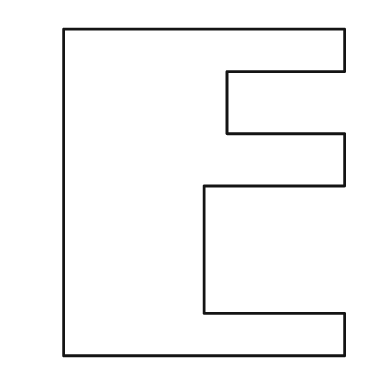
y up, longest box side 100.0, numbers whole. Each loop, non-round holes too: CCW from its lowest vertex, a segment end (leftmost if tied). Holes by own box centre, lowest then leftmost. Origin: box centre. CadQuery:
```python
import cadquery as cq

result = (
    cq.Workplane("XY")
    .moveTo(-43.0, -50.0)
    .lineTo(43.0, -50.0)
    .lineTo(43.0, -37.0)
    .lineTo(0.0, -37.0)
    .lineTo(0.0, 2.0)
    .lineTo(43.0, 2.0)
    .lineTo(43.0, 18.0)
    .lineTo(7.0, 18.0)
    .lineTo(7.0, 37.0)
    .lineTo(43.0, 37.0)
    .lineTo(43.0, 50.0)
    .lineTo(-43.0, 50.0)
    .close()
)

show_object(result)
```